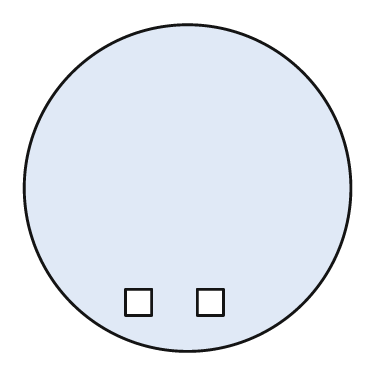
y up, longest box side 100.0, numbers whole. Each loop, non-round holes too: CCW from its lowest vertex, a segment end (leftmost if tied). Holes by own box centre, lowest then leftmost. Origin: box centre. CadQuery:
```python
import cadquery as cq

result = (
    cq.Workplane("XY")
    .moveTo(0.0, 0.0)
    .circle(50.0)
    .moveTo(-19.0, -39.0)
    .lineTo(-11.0, -39.0)
    .lineTo(-11.0, -31.0)
    .lineTo(-19.0, -31.0)
    .close()
    .moveTo(3.0, -39.0)
    .lineTo(11.0, -39.0)
    .lineTo(11.0, -31.0)
    .lineTo(3.0, -31.0)
    .close()
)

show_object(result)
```